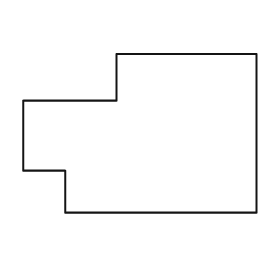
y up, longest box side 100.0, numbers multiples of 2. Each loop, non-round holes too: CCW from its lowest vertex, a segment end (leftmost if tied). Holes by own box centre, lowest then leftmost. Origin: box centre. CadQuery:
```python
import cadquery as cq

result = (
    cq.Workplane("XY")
    .moveTo(-32.0, -34.0)
    .lineTo(50.0, -34.0)
    .lineTo(50.0, 34.0)
    .lineTo(-10.0, 34.0)
    .lineTo(-10.0, 14.0)
    .lineTo(-50.0, 14.0)
    .lineTo(-50.0, -16.0)
    .lineTo(-32.0, -16.0)
    .close()
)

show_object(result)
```